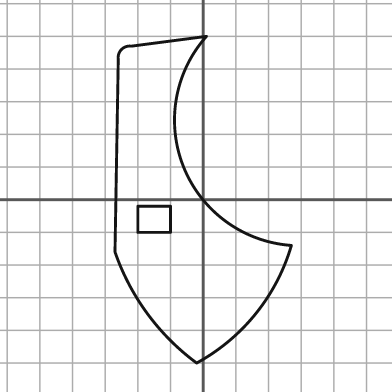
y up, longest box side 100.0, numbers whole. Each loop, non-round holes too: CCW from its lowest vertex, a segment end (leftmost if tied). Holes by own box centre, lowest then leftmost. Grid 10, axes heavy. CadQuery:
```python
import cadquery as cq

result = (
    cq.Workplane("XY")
    .moveTo(-2.0, -50.0)
    .threePointArc((16.0, -35.0), (27.0, -14.0))
    .threePointArc((-6.0, 10.0), (1.0, 50.0))
    .lineTo(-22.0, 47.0)
    .threePointArc((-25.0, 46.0), (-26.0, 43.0))
    .lineTo(-27.0, -16.0)
    .threePointArc((-17.0, -35.0), (-2.0, -50.0))
    .close()
    .moveTo(-20.0, -10.0)
    .lineTo(-10.0, -10.0)
    .lineTo(-10.0, -2.0)
    .lineTo(-20.0, -2.0)
    .close()
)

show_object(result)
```